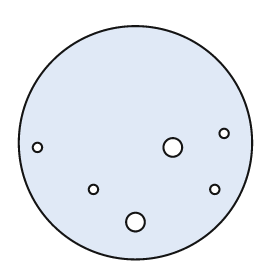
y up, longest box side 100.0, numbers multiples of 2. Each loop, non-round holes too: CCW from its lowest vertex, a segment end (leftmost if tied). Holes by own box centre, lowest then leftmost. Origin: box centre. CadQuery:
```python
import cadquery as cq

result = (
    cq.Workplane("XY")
    .moveTo(0.0, 0.0)
    .circle(50.0)
    .moveTo(0.0, -34.0)
    .circle(4.0)
    .moveTo(-18.0, -20.0)
    .circle(2.0)
    .moveTo(34.0, -20.0)
    .circle(2.0)
    .moveTo(-42.0, -2.0)
    .circle(2.0)
    .moveTo(16.0, -2.0)
    .circle(4.0)
    .moveTo(38.0, 4.0)
    .circle(2.0)
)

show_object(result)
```